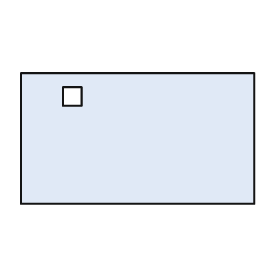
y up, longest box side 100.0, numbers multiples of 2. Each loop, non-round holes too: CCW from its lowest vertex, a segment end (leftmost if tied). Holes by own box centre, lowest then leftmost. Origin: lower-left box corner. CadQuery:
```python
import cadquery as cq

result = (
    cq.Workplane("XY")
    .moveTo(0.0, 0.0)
    .lineTo(100.0, 0.0)
    .lineTo(100.0, 56.0)
    .lineTo(0.0, 56.0)
    .close()
    .moveTo(18.0, 42.0)
    .lineTo(26.0, 42.0)
    .lineTo(26.0, 50.0)
    .lineTo(18.0, 50.0)
    .close()
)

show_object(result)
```